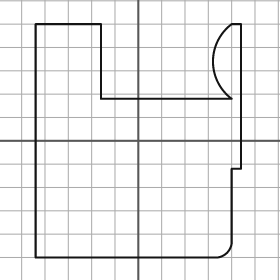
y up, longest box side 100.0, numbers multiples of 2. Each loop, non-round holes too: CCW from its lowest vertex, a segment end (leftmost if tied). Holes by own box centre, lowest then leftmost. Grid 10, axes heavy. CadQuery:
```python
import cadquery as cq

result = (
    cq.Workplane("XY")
    .moveTo(-44.0, -50.0)
    .lineTo(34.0, -50.0)
    .threePointArc((38.0, -48.0), (40.0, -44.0))
    .lineTo(40.0, -12.0)
    .lineTo(44.0, -12.0)
    .lineTo(44.0, 50.0)
    .lineTo(40.0, 50.0)
    .threePointArc((32.0, 34.0), (40.0, 18.0))
    .lineTo(-16.0, 18.0)
    .lineTo(-16.0, 50.0)
    .lineTo(-44.0, 50.0)
    .close()
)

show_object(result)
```